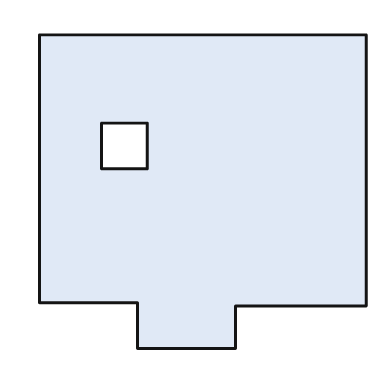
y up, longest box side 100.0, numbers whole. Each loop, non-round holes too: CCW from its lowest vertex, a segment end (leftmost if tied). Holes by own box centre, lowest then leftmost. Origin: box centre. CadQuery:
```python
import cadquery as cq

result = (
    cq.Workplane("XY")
    .moveTo(-20.0, -48.0)
    .lineTo(10.0, -48.0)
    .lineTo(10.0, -35.0)
    .lineTo(50.0, -35.0)
    .lineTo(50.0, 48.0)
    .lineTo(-50.0, 48.0)
    .lineTo(-50.0, -34.0)
    .lineTo(-20.0, -34.0)
    .close()
    .moveTo(-31.0, 7.0)
    .lineTo(-17.0, 7.0)
    .lineTo(-17.0, 21.0)
    .lineTo(-31.0, 21.0)
    .close()
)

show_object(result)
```